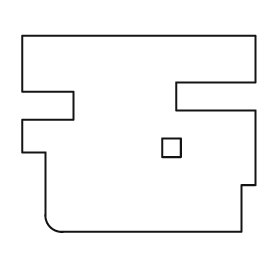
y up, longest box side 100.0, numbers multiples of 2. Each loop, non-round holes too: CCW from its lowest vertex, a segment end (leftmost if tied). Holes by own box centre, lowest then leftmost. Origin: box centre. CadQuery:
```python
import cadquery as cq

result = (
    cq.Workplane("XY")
    .moveTo(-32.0, -42.0)
    .lineTo(44.0, -42.0)
    .lineTo(44.0, -22.0)
    .lineTo(50.0, -22.0)
    .lineTo(50.0, 10.0)
    .lineTo(16.0, 10.0)
    .lineTo(16.0, 22.0)
    .lineTo(50.0, 22.0)
    .lineTo(50.0, 42.0)
    .lineTo(-50.0, 42.0)
    .lineTo(-50.0, 18.0)
    .lineTo(-28.0, 18.0)
    .lineTo(-28.0, 6.0)
    .lineTo(-50.0, 6.0)
    .lineTo(-50.0, -8.0)
    .lineTo(-40.0, -8.0)
    .lineTo(-40.0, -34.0)
    .threePointArc((-38.0, -40.0), (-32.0, -42.0))
    .close()
    .moveTo(10.0, -10.0)
    .lineTo(18.0, -10.0)
    .lineTo(18.0, -2.0)
    .lineTo(10.0, -2.0)
    .close()
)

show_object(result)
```